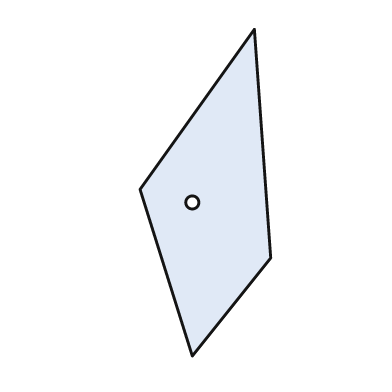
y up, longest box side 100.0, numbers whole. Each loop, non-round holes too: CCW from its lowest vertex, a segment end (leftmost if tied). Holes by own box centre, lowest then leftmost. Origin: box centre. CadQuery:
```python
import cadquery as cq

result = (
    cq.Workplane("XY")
    .moveTo(-4.0, -50.0)
    .lineTo(20.0, -20.0)
    .lineTo(15.0, 50.0)
    .lineTo(-20.0, 1.0)
    .close()
    .moveTo(-4.0, -3.0)
    .circle(2.0)
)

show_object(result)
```